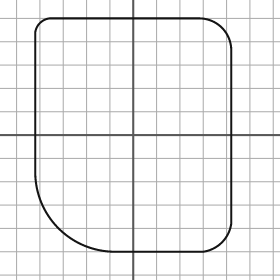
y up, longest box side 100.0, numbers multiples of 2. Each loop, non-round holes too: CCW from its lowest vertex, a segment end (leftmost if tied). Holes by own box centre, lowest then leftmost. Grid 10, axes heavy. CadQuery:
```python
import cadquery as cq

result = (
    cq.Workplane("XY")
    .moveTo(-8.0, -50.0)
    .lineTo(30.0, -50.0)
    .threePointArc((38.0, -46.0), (42.0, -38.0))
    .lineTo(42.0, 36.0)
    .threePointArc((38.0, 46.0), (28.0, 50.0))
    .lineTo(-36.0, 50.0)
    .threePointArc((-40.0, 48.0), (-42.0, 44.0))
    .lineTo(-42.0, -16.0)
    .threePointArc((-32.0, -40.0), (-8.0, -50.0))
    .close()
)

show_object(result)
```